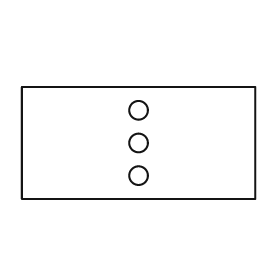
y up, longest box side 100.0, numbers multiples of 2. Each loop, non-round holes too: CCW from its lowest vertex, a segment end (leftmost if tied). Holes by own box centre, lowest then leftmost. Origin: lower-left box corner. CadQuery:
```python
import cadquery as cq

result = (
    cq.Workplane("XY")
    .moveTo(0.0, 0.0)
    .lineTo(100.0, 0.0)
    .lineTo(100.0, 48.0)
    .lineTo(0.0, 48.0)
    .close()
    .moveTo(50.0, 10.0)
    .circle(4.0)
    .moveTo(50.0, 24.0)
    .circle(4.0)
    .moveTo(50.0, 38.0)
    .circle(4.0)
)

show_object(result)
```